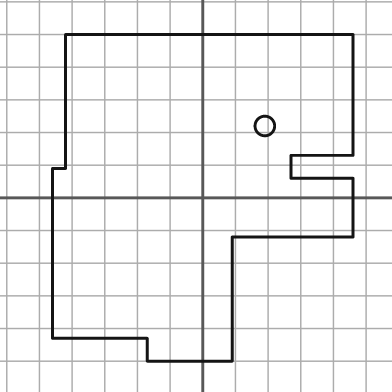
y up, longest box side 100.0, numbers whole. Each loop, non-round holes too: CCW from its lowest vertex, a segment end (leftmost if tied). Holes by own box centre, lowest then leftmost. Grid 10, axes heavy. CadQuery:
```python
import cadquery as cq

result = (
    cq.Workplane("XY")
    .moveTo(-17.0, -50.0)
    .lineTo(9.0, -50.0)
    .lineTo(9.0, -12.0)
    .lineTo(46.0, -12.0)
    .lineTo(46.0, 6.0)
    .lineTo(27.0, 6.0)
    .lineTo(27.0, 13.0)
    .lineTo(46.0, 13.0)
    .lineTo(46.0, 50.0)
    .lineTo(-42.0, 50.0)
    .lineTo(-42.0, 9.0)
    .lineTo(-46.0, 9.0)
    .lineTo(-46.0, -43.0)
    .lineTo(-17.0, -43.0)
    .close()
    .moveTo(19.0, 22.0)
    .circle(3.0)
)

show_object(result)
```